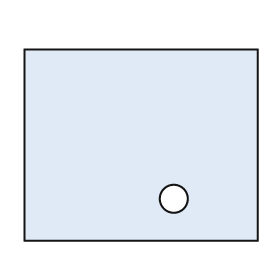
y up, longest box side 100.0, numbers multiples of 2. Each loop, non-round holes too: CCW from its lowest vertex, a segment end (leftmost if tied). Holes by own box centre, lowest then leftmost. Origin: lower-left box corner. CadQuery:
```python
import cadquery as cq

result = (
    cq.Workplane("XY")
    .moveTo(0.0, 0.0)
    .lineTo(100.0, 0.0)
    .lineTo(100.0, 82.0)
    .lineTo(0.0, 82.0)
    .close()
    .moveTo(64.0, 18.0)
    .circle(6.0)
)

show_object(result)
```